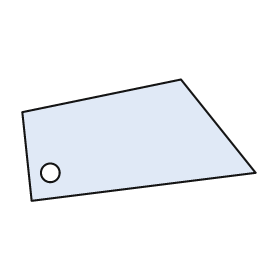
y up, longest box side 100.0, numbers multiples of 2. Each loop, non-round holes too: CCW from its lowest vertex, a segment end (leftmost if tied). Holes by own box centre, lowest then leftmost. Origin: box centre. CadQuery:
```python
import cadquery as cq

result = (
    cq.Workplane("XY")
    .moveTo(-46.0, -26.0)
    .lineTo(50.0, -14.0)
    .lineTo(18.0, 26.0)
    .lineTo(-50.0, 12.0)
    .close()
    .moveTo(-38.0, -14.0)
    .circle(4.0)
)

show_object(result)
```